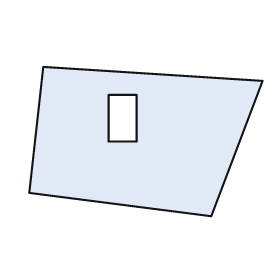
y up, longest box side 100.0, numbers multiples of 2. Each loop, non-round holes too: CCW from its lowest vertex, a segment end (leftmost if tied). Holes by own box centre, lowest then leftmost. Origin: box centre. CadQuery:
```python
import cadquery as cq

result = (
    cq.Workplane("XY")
    .moveTo(28.0, -32.0)
    .lineTo(50.0, 26.0)
    .lineTo(-44.0, 32.0)
    .lineTo(-50.0, -22.0)
    .close()
    .moveTo(-16.0, 0.0)
    .lineTo(-4.0, 0.0)
    .lineTo(-4.0, 20.0)
    .lineTo(-16.0, 20.0)
    .close()
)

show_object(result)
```